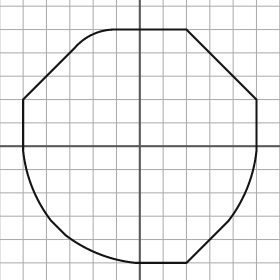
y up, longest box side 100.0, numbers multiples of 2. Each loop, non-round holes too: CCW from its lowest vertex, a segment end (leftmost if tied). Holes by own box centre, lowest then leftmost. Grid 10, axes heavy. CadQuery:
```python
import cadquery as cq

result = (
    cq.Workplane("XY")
    .moveTo(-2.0, -50.0)
    .lineTo(20.0, -50.0)
    .lineTo(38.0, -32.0)
    .threePointArc((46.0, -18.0), (50.0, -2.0))
    .lineTo(50.0, 20.0)
    .lineTo(20.0, 50.0)
    .lineTo(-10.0, 50.0)
    .threePointArc((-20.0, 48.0), (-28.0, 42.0))
    .lineTo(-50.0, 20.0)
    .lineTo(-50.0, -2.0)
    .threePointArc((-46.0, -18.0), (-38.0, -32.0))
    .lineTo(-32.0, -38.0)
    .threePointArc((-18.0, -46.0), (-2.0, -50.0))
    .close()
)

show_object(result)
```